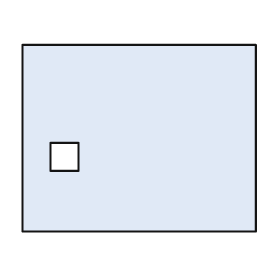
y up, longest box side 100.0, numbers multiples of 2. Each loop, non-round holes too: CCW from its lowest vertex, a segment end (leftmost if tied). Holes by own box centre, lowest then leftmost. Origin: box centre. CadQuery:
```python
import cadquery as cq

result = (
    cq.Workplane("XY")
    .moveTo(-50.0, -40.0)
    .lineTo(50.0, -40.0)
    .lineTo(50.0, 40.0)
    .lineTo(-50.0, 40.0)
    .close()
    .moveTo(-38.0, -14.0)
    .lineTo(-26.0, -14.0)
    .lineTo(-26.0, -2.0)
    .lineTo(-38.0, -2.0)
    .close()
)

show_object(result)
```